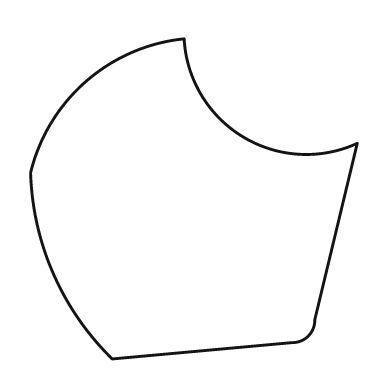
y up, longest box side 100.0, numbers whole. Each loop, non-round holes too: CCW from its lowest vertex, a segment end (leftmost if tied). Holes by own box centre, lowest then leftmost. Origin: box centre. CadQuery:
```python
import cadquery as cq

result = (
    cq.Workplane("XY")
    .moveTo(-25.0, -49.0)
    .lineTo(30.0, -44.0)
    .threePointArc((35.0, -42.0), (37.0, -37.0))
    .lineTo(50.0, 17.0)
    .threePointArc((15.0, 19.0), (-3.0, 49.0))
    .threePointArc((-33.0, 36.0), (-50.0, 8.0))
    .threePointArc((-43.0, -23.0), (-25.0, -49.0))
    .close()
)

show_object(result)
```